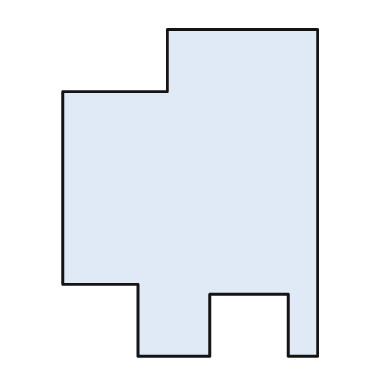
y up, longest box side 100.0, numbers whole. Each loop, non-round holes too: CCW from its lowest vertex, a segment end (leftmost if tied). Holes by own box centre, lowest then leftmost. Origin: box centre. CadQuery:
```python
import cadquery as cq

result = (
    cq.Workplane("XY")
    .moveTo(-16.0, -50.0)
    .lineTo(6.0, -50.0)
    .lineTo(6.0, -31.0)
    .lineTo(30.0, -31.0)
    .lineTo(30.0, -50.0)
    .lineTo(39.0, -50.0)
    .lineTo(39.0, 50.0)
    .lineTo(-7.0, 50.0)
    .lineTo(-7.0, 31.0)
    .lineTo(-39.0, 31.0)
    .lineTo(-39.0, -28.0)
    .lineTo(-16.0, -28.0)
    .close()
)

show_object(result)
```